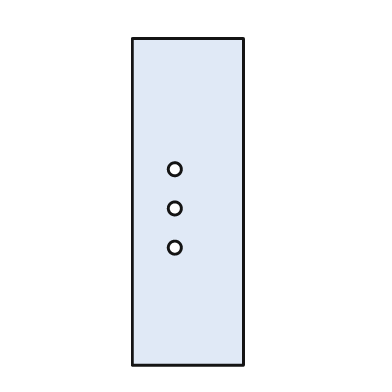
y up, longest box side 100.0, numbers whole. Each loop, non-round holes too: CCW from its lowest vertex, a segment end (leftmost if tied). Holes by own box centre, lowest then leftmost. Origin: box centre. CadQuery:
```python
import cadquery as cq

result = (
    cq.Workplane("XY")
    .moveTo(-17.0, -50.0)
    .lineTo(17.0, -50.0)
    .lineTo(17.0, 50.0)
    .lineTo(-17.0, 50.0)
    .close()
    .moveTo(-4.0, -14.0)
    .circle(2.0)
    .moveTo(-4.0, -2.0)
    .circle(2.0)
    .moveTo(-4.0, 10.0)
    .circle(2.0)
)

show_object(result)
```